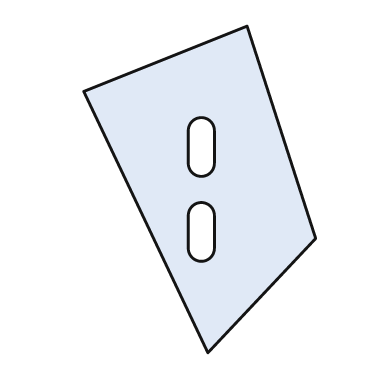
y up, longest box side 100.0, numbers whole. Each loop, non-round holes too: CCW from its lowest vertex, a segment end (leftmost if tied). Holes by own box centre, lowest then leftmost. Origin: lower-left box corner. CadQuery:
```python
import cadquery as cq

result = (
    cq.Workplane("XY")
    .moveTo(38.0, 0.0)
    .lineTo(71.0, 35.0)
    .lineTo(50.0, 100.0)
    .lineTo(0.0, 80.0)
    .close()
    .moveTo(32.0, 32.0)
    .threePointArc((36.0, 28.0), (40.0, 32.0))
    .lineTo(40.0, 42.0)
    .threePointArc((36.0, 46.0), (32.0, 42.0))
    .close()
    .moveTo(32.0, 58.0)
    .threePointArc((36.0, 54.0), (40.0, 58.0))
    .lineTo(40.0, 68.0)
    .threePointArc((36.0, 72.0), (32.0, 68.0))
    .close()
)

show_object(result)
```